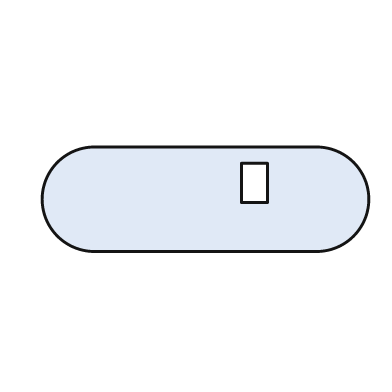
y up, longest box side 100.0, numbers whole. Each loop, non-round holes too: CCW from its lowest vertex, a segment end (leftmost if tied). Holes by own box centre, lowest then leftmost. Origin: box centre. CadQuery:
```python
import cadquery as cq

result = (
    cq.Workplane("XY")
    .moveTo(-34.0, -16.0)
    .lineTo(34.0, -16.0)
    .threePointArc((50.0, 0.0), (34.0, 16.0))
    .lineTo(-34.0, 16.0)
    .threePointArc((-50.0, 0.0), (-34.0, -16.0))
    .close()
    .moveTo(11.0, -1.0)
    .lineTo(19.0, -1.0)
    .lineTo(19.0, 11.0)
    .lineTo(11.0, 11.0)
    .close()
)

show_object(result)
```